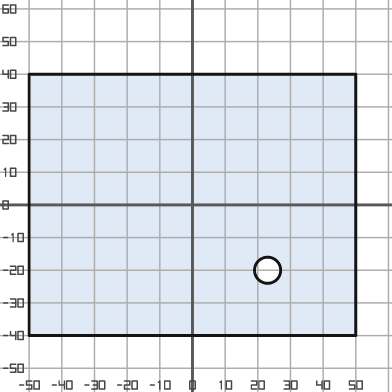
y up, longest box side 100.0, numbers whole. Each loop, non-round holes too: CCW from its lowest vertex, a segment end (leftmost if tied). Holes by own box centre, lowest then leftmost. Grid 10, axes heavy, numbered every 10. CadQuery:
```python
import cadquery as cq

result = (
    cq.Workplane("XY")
    .moveTo(-50.0, -40.0)
    .lineTo(50.0, -40.0)
    .lineTo(50.0, 40.0)
    .lineTo(-50.0, 40.0)
    .close()
    .moveTo(23.0, -20.0)
    .circle(4.0)
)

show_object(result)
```